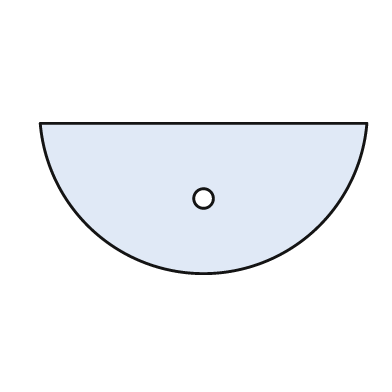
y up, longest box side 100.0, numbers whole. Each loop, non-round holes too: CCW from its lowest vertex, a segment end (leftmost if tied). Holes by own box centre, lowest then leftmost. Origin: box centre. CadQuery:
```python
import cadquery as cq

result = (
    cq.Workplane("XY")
    .moveTo(-50.0, 23.0)
    .threePointArc((0.0, -23.0), (50.0, 23.0))
    .close()
    .moveTo(0.0, 0.0)
    .circle(3.0)
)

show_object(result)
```